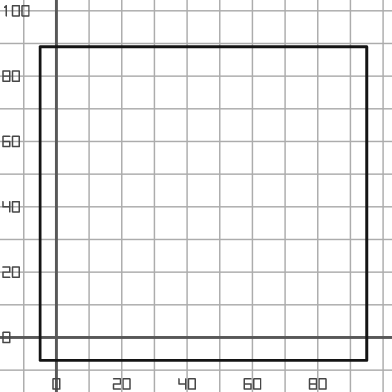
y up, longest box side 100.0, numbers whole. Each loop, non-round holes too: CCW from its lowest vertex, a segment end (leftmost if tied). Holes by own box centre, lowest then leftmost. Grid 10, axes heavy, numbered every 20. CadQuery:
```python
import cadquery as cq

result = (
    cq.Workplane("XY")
    .moveTo(-5.0, -7.0)
    .lineTo(95.0, -7.0)
    .lineTo(95.0, 89.0)
    .lineTo(-5.0, 89.0)
    .close()
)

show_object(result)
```